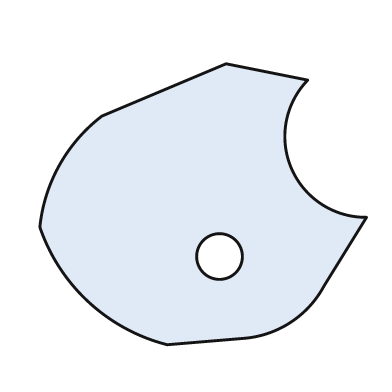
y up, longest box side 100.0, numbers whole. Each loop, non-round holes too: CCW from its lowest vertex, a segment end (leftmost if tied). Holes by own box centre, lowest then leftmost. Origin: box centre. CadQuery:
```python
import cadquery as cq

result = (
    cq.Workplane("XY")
    .moveTo(-11.0, -43.0)
    .lineTo(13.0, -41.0)
    .threePointArc((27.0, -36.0), (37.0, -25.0))
    .lineTo(50.0, -4.0)
    .threePointArc((27.0, 11.0), (32.0, 38.0))
    .lineTo(7.0, 43.0)
    .lineTo(-31.0, 27.0)
    .threePointArc((-44.0, 12.0), (-50.0, -7.0))
    .threePointArc((-35.0, -30.0), (-11.0, -43.0))
    .close()
    .moveTo(5.0, -16.0)
    .circle(7.0)
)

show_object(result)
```